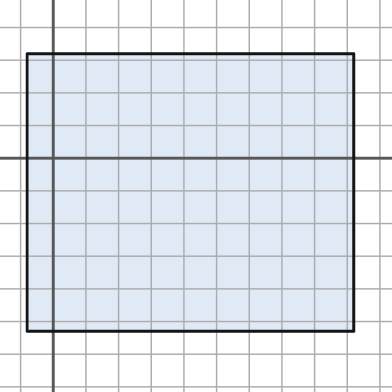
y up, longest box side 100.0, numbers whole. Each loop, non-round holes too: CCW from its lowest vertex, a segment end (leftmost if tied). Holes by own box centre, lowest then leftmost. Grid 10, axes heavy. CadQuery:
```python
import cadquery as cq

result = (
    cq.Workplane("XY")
    .moveTo(-8.0, -53.0)
    .lineTo(92.0, -53.0)
    .lineTo(92.0, 32.0)
    .lineTo(-8.0, 32.0)
    .close()
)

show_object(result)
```